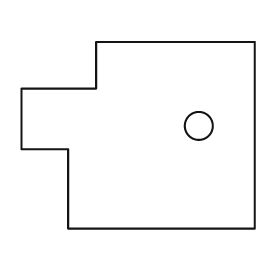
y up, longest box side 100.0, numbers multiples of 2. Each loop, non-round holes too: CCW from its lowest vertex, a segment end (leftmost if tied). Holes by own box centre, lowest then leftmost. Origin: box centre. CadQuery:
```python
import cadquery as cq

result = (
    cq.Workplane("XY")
    .moveTo(-30.0, -40.0)
    .lineTo(50.0, -40.0)
    .lineTo(50.0, 40.0)
    .lineTo(-18.0, 40.0)
    .lineTo(-18.0, 20.0)
    .lineTo(-50.0, 20.0)
    .lineTo(-50.0, -6.0)
    .lineTo(-30.0, -6.0)
    .close()
    .moveTo(26.0, 4.0)
    .circle(6.0)
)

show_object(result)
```